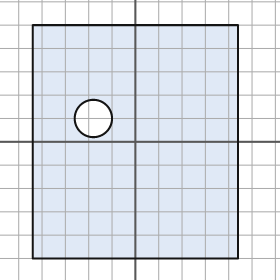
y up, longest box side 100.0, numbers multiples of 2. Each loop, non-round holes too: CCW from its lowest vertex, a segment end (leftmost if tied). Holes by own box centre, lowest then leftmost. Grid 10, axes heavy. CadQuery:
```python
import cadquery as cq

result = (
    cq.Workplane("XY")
    .moveTo(-44.0, -50.0)
    .lineTo(44.0, -50.0)
    .lineTo(44.0, 50.0)
    .lineTo(-44.0, 50.0)
    .close()
    .moveTo(-18.0, 10.0)
    .circle(8.0)
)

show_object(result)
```